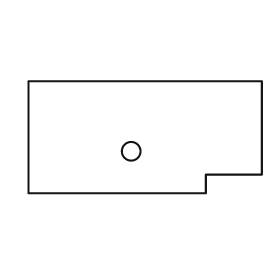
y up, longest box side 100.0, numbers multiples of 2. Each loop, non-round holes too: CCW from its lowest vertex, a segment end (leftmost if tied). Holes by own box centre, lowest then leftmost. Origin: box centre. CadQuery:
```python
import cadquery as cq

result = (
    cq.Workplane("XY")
    .moveTo(-50.0, -24.0)
    .lineTo(26.0, -24.0)
    .lineTo(26.0, -16.0)
    .lineTo(50.0, -16.0)
    .lineTo(50.0, 24.0)
    .lineTo(-50.0, 24.0)
    .close()
    .moveTo(-6.0, -6.0)
    .circle(4.0)
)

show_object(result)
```